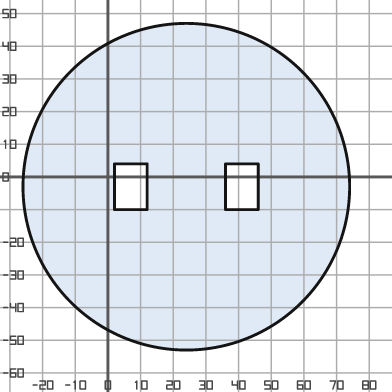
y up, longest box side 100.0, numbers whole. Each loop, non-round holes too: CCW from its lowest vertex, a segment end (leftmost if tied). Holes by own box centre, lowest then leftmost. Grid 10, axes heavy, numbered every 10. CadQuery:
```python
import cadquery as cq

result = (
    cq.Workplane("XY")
    .moveTo(24.0, -3.0)
    .circle(50.0)
    .moveTo(2.0, -10.0)
    .lineTo(12.0, -10.0)
    .lineTo(12.0, 4.0)
    .lineTo(2.0, 4.0)
    .close()
    .moveTo(36.0, -10.0)
    .lineTo(46.0, -10.0)
    .lineTo(46.0, 4.0)
    .lineTo(36.0, 4.0)
    .close()
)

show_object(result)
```